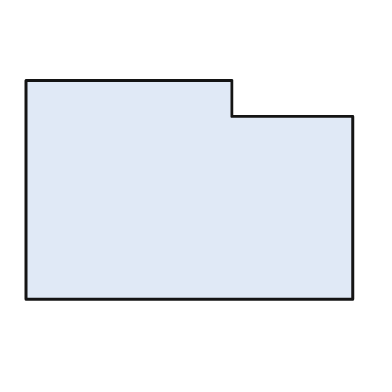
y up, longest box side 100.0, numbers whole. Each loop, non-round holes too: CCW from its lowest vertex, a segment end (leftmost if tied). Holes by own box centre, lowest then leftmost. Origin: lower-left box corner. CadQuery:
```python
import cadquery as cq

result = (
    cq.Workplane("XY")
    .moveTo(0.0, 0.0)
    .lineTo(100.0, 0.0)
    .lineTo(100.0, 56.0)
    .lineTo(63.0, 56.0)
    .lineTo(63.0, 67.0)
    .lineTo(0.0, 67.0)
    .close()
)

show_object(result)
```